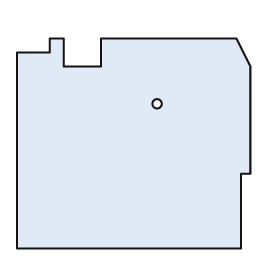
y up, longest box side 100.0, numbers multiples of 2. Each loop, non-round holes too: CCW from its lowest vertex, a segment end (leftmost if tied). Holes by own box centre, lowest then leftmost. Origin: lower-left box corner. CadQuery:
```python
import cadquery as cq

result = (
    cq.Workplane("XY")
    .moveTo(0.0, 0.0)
    .lineTo(96.0, 0.0)
    .lineTo(96.0, 32.0)
    .lineTo(100.0, 32.0)
    .lineTo(100.0, 78.0)
    .lineTo(94.0, 90.0)
    .lineTo(36.0, 90.0)
    .lineTo(36.0, 78.0)
    .lineTo(20.0, 78.0)
    .lineTo(20.0, 90.0)
    .lineTo(14.0, 90.0)
    .lineTo(14.0, 84.0)
    .lineTo(0.0, 84.0)
    .close()
    .moveTo(60.0, 62.0)
    .circle(2.0)
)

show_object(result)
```